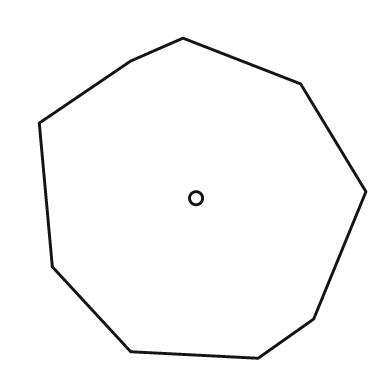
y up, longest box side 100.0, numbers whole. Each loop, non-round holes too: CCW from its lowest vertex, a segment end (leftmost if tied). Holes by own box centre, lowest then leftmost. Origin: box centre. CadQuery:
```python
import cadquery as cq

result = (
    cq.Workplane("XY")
    .moveTo(17.0, -49.0)
    .lineTo(34.0, -37.0)
    .lineTo(50.0, 2.0)
    .lineTo(30.0, 35.0)
    .lineTo(-6.0, 49.0)
    .lineTo(-22.0, 42.0)
    .lineTo(-50.0, 23.0)
    .lineTo(-46.0, -21.0)
    .lineTo(-22.0, -47.0)
    .close()
    .moveTo(-2.0, 0.0)
    .circle(2.0)
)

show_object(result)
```